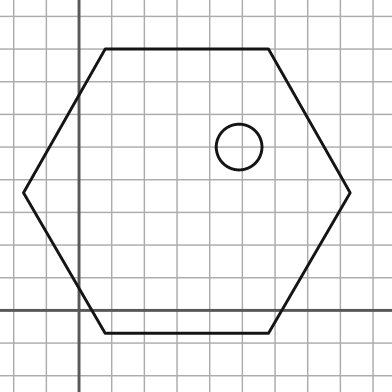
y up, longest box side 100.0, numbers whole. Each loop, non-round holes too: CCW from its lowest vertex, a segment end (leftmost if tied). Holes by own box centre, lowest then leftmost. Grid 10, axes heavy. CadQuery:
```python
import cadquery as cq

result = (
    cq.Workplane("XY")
    .moveTo(8.0, -7.0)
    .lineTo(58.0, -7.0)
    .lineTo(83.0, 36.0)
    .lineTo(58.0, 80.0)
    .lineTo(8.0, 80.0)
    .lineTo(-17.0, 36.0)
    .close()
    .moveTo(49.0, 50.0)
    .circle(7.0)
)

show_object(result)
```